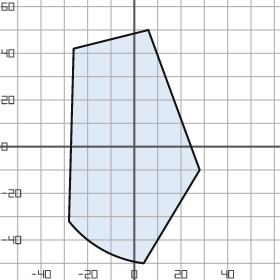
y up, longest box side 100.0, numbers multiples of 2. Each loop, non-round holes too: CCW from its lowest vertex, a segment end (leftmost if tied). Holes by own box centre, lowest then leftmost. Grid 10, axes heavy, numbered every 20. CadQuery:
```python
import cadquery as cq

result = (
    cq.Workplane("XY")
    .moveTo(4.0, -50.0)
    .lineTo(28.0, -10.0)
    .lineTo(6.0, 50.0)
    .lineTo(-26.0, 42.0)
    .lineTo(-28.0, -32.0)
    .threePointArc((-14.0, -44.0), (4.0, -50.0))
    .close()
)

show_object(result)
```